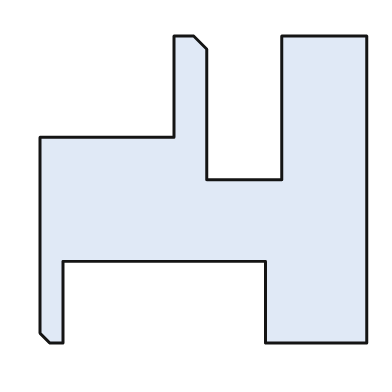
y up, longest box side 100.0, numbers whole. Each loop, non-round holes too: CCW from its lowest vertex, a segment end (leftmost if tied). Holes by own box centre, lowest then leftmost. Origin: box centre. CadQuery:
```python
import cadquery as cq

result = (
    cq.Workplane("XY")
    .moveTo(-47.0, -47.0)
    .lineTo(-43.0, -47.0)
    .lineTo(-43.0, -22.0)
    .lineTo(19.0, -22.0)
    .lineTo(19.0, -47.0)
    .lineTo(50.0, -47.0)
    .lineTo(50.0, 47.0)
    .lineTo(24.0, 47.0)
    .lineTo(24.0, 3.0)
    .lineTo(1.0, 3.0)
    .lineTo(1.0, 43.0)
    .lineTo(-3.0, 47.0)
    .lineTo(-9.0, 47.0)
    .lineTo(-9.0, 16.0)
    .lineTo(-50.0, 16.0)
    .lineTo(-50.0, -44.0)
    .close()
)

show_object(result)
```